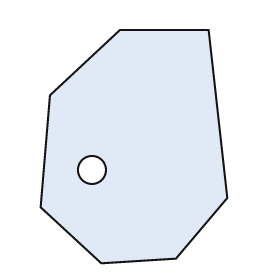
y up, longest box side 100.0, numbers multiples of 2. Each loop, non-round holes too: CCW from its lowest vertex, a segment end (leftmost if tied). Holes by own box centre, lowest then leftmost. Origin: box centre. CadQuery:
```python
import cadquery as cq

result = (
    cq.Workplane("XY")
    .moveTo(-14.0, -50.0)
    .lineTo(18.0, -48.0)
    .lineTo(40.0, -22.0)
    .lineTo(32.0, 50.0)
    .lineTo(-6.0, 50.0)
    .lineTo(-36.0, 22.0)
    .lineTo(-40.0, -26.0)
    .close()
    .moveTo(-18.0, -10.0)
    .circle(6.0)
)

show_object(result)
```